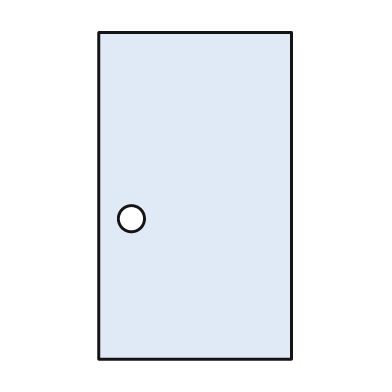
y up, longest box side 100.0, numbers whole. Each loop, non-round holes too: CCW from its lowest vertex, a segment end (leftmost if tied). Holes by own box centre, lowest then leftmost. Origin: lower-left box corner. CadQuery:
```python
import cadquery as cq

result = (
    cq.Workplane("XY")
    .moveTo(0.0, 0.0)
    .lineTo(59.0, 0.0)
    .lineTo(59.0, 100.0)
    .lineTo(0.0, 100.0)
    .close()
    .moveTo(10.0, 43.0)
    .circle(4.0)
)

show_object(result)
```